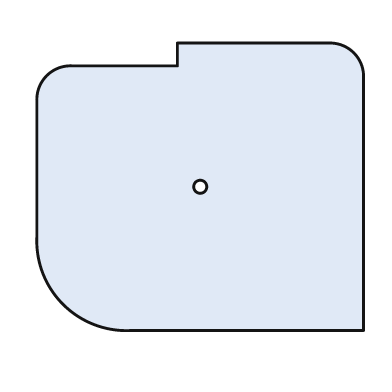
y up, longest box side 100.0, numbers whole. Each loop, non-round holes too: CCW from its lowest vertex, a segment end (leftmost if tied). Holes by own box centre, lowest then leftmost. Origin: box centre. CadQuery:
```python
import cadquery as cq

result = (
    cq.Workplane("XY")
    .moveTo(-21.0, -44.0)
    .lineTo(50.0, -44.0)
    .lineTo(50.0, 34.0)
    .threePointArc((47.0, 41.0), (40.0, 44.0))
    .lineTo(-7.0, 44.0)
    .lineTo(-7.0, 37.0)
    .lineTo(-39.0, 37.0)
    .threePointArc((-47.0, 34.0), (-50.0, 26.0))
    .lineTo(-50.0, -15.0)
    .threePointArc((-42.0, -36.0), (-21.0, -44.0))
    .close()
    .moveTo(0.0, 0.0)
    .circle(2.0)
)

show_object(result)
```